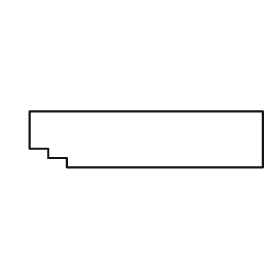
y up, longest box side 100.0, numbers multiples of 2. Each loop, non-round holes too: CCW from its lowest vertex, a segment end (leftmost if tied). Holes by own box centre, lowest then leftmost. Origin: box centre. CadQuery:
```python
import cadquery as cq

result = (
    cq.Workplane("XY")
    .moveTo(-34.0, -12.0)
    .lineTo(50.0, -12.0)
    .lineTo(50.0, 12.0)
    .lineTo(-50.0, 12.0)
    .lineTo(-50.0, -4.0)
    .lineTo(-42.0, -4.0)
    .lineTo(-42.0, -8.0)
    .lineTo(-34.0, -8.0)
    .close()
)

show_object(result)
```